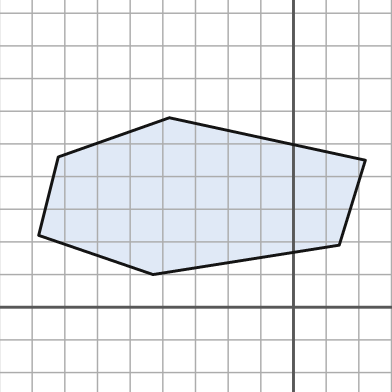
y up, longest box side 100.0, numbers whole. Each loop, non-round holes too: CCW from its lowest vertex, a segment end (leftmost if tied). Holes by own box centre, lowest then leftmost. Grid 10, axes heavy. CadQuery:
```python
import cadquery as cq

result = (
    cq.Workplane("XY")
    .moveTo(-43.0, 10.0)
    .lineTo(14.0, 19.0)
    .lineTo(22.0, 45.0)
    .lineTo(-38.0, 58.0)
    .lineTo(-72.0, 46.0)
    .lineTo(-78.0, 22.0)
    .close()
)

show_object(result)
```